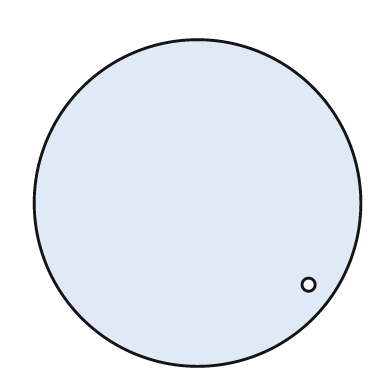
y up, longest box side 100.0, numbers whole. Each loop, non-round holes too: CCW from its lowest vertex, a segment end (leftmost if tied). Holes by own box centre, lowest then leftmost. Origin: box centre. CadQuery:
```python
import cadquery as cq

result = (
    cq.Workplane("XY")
    .moveTo(0.0, 0.0)
    .circle(50.0)
    .moveTo(34.0, -25.0)
    .circle(2.0)
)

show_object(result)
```